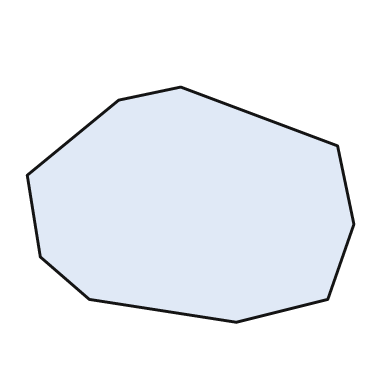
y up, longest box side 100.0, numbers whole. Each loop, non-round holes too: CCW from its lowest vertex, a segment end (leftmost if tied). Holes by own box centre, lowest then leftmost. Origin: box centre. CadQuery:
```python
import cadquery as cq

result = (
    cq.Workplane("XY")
    .moveTo(14.0, -36.0)
    .lineTo(42.0, -29.0)
    .lineTo(50.0, -6.0)
    .lineTo(45.0, 18.0)
    .lineTo(-3.0, 36.0)
    .lineTo(-22.0, 32.0)
    .lineTo(-50.0, 9.0)
    .lineTo(-46.0, -16.0)
    .lineTo(-31.0, -29.0)
    .close()
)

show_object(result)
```